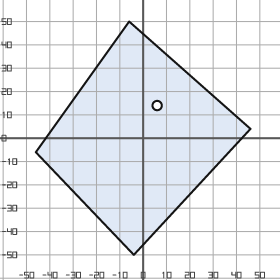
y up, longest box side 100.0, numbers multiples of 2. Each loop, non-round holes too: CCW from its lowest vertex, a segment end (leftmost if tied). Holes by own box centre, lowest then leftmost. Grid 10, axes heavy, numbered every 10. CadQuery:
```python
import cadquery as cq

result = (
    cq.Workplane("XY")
    .moveTo(-4.0, -50.0)
    .lineTo(46.0, 4.0)
    .lineTo(-6.0, 50.0)
    .lineTo(-46.0, -6.0)
    .close()
    .moveTo(6.0, 14.0)
    .circle(2.0)
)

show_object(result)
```